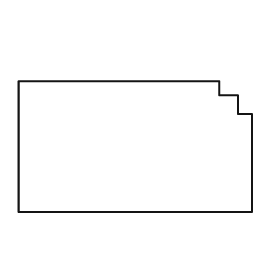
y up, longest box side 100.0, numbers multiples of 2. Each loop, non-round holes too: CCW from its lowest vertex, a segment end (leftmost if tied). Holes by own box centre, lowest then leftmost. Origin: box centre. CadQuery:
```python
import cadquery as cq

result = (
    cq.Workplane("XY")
    .moveTo(-50.0, -28.0)
    .lineTo(50.0, -28.0)
    .lineTo(50.0, 14.0)
    .lineTo(44.0, 14.0)
    .lineTo(44.0, 22.0)
    .lineTo(36.0, 22.0)
    .lineTo(36.0, 28.0)
    .lineTo(-50.0, 28.0)
    .close()
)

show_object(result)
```